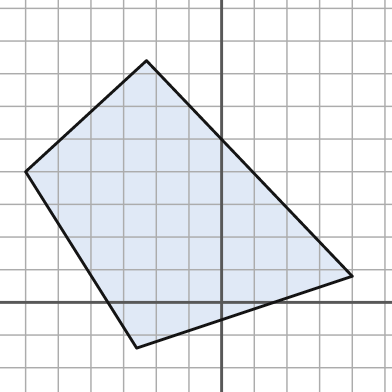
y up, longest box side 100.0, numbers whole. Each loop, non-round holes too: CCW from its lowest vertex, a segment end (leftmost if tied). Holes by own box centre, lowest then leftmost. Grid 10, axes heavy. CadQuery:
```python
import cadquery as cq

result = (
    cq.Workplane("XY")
    .moveTo(-26.0, -14.0)
    .lineTo(40.0, 8.0)
    .lineTo(-23.0, 74.0)
    .lineTo(-60.0, 40.0)
    .close()
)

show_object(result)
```